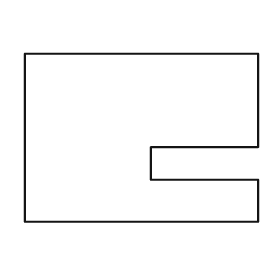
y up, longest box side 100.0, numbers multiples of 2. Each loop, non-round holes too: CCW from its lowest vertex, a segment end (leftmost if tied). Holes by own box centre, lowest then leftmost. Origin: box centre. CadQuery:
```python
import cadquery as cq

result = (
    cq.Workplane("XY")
    .moveTo(-50.0, -36.0)
    .lineTo(50.0, -36.0)
    .lineTo(50.0, -18.0)
    .lineTo(4.0, -18.0)
    .lineTo(4.0, -4.0)
    .lineTo(50.0, -4.0)
    .lineTo(50.0, 36.0)
    .lineTo(-50.0, 36.0)
    .close()
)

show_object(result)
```